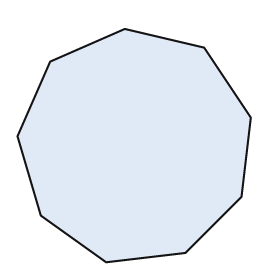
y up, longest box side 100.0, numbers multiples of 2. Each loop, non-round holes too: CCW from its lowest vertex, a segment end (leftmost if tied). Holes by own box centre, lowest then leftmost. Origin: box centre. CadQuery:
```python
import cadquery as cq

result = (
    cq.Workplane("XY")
    .moveTo(-12.0, -50.0)
    .lineTo(22.0, -46.0)
    .lineTo(46.0, -22.0)
    .lineTo(50.0, 12.0)
    .lineTo(30.0, 42.0)
    .lineTo(-4.0, 50.0)
    .lineTo(-36.0, 36.0)
    .lineTo(-50.0, 4.0)
    .lineTo(-40.0, -30.0)
    .close()
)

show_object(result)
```